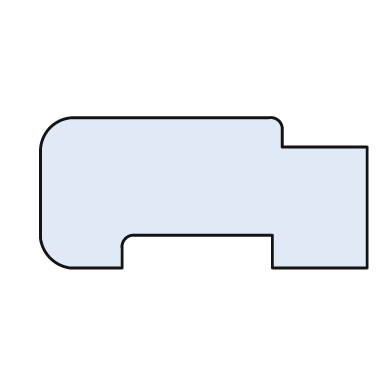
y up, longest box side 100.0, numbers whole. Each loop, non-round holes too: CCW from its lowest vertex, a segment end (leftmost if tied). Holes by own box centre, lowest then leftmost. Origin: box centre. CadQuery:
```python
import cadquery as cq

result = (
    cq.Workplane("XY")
    .moveTo(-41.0, -23.0)
    .lineTo(-25.0, -23.0)
    .lineTo(-25.0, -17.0)
    .threePointArc((-24.0, -14.0), (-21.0, -13.0))
    .lineTo(21.0, -13.0)
    .lineTo(21.0, -23.0)
    .lineTo(50.0, -23.0)
    .lineTo(50.0, 14.0)
    .lineTo(24.0, 14.0)
    .lineTo(24.0, 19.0)
    .threePointArc((23.0, 22.0), (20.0, 23.0))
    .lineTo(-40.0, 23.0)
    .threePointArc((-47.0, 20.0), (-50.0, 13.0))
    .lineTo(-50.0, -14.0)
    .threePointArc((-47.0, -20.0), (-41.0, -23.0))
    .close()
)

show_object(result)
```